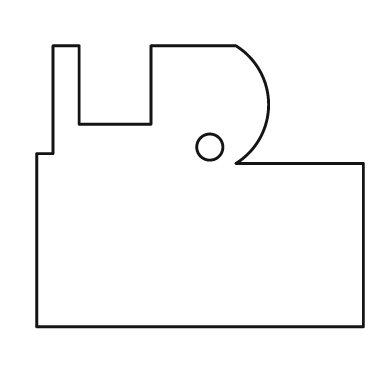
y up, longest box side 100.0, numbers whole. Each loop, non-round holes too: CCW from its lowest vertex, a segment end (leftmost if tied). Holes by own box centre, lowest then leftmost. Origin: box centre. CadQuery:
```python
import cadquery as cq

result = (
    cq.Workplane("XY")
    .moveTo(-50.0, -43.0)
    .lineTo(50.0, -43.0)
    .lineTo(50.0, 7.0)
    .lineTo(11.0, 7.0)
    .threePointArc((21.0, 25.0), (11.0, 43.0))
    .lineTo(-15.0, 43.0)
    .lineTo(-15.0, 19.0)
    .lineTo(-37.0, 19.0)
    .lineTo(-37.0, 43.0)
    .lineTo(-45.0, 43.0)
    .lineTo(-45.0, 10.0)
    .lineTo(-50.0, 10.0)
    .close()
    .moveTo(3.0, 12.0)
    .circle(4.0)
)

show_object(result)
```